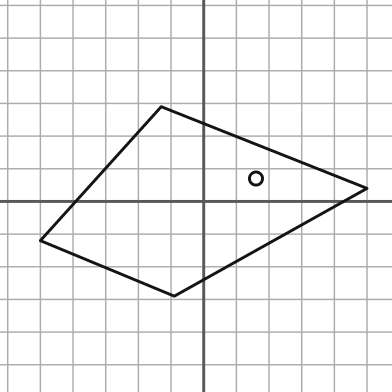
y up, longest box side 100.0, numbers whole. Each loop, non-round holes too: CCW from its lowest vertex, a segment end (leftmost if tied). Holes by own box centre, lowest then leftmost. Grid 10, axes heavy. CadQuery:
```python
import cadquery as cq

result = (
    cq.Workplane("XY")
    .moveTo(-9.0, -29.0)
    .lineTo(50.0, 4.0)
    .lineTo(-13.0, 29.0)
    .lineTo(-50.0, -12.0)
    .close()
    .moveTo(16.0, 7.0)
    .circle(2.0)
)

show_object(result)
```